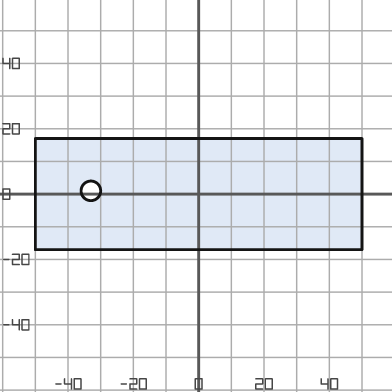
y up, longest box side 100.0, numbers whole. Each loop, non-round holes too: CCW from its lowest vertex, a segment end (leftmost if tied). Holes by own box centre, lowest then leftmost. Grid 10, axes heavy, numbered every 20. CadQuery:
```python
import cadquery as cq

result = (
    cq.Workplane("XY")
    .moveTo(-50.0, -17.0)
    .lineTo(50.0, -17.0)
    .lineTo(50.0, 17.0)
    .lineTo(-50.0, 17.0)
    .close()
    .moveTo(-33.0, 1.0)
    .circle(3.0)
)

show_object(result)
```